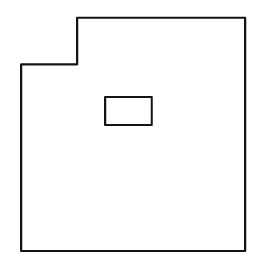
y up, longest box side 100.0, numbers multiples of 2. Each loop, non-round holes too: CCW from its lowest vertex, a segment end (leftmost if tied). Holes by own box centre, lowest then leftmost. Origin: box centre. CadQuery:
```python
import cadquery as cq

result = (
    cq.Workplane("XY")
    .moveTo(-48.0, -50.0)
    .lineTo(48.0, -50.0)
    .lineTo(48.0, 50.0)
    .lineTo(-24.0, 50.0)
    .lineTo(-24.0, 30.0)
    .lineTo(-48.0, 30.0)
    .close()
    .moveTo(-12.0, 4.0)
    .lineTo(8.0, 4.0)
    .lineTo(8.0, 16.0)
    .lineTo(-12.0, 16.0)
    .close()
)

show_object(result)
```